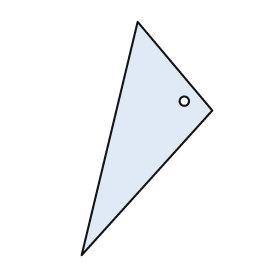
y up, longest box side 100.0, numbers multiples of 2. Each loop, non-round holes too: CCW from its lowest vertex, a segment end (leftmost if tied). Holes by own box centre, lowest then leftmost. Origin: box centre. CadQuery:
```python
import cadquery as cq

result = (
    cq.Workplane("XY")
    .moveTo(-28.0, -50.0)
    .lineTo(28.0, 12.0)
    .lineTo(-4.0, 50.0)
    .close()
    .moveTo(16.0, 16.0)
    .circle(2.0)
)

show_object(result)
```